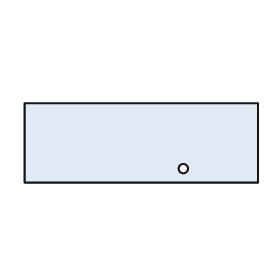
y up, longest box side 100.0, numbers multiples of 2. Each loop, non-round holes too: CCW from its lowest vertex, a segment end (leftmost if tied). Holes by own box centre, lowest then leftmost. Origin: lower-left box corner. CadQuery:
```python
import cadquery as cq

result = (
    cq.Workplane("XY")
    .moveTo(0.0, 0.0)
    .lineTo(100.0, 0.0)
    .lineTo(100.0, 34.0)
    .lineTo(0.0, 34.0)
    .close()
    .moveTo(68.0, 6.0)
    .circle(2.0)
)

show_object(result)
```